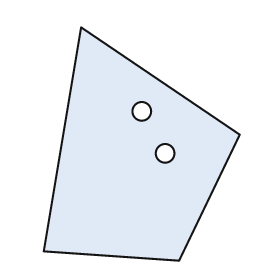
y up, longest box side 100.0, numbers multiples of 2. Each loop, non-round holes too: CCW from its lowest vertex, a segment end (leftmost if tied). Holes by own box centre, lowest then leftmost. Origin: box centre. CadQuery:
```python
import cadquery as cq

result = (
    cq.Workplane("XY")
    .moveTo(16.0, -50.0)
    .lineTo(42.0, 4.0)
    .lineTo(-26.0, 50.0)
    .lineTo(-42.0, -46.0)
    .close()
    .moveTo(10.0, -4.0)
    .circle(4.0)
    .moveTo(0.0, 14.0)
    .circle(4.0)
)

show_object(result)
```